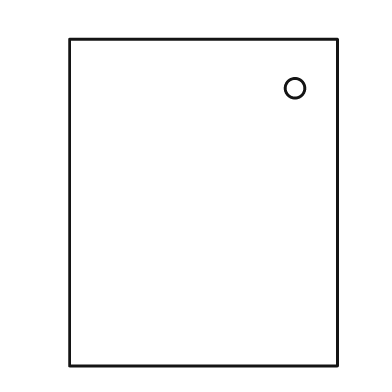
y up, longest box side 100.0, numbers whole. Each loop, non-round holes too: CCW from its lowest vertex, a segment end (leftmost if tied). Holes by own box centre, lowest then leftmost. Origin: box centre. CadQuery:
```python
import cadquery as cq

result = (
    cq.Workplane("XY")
    .moveTo(-41.0, -50.0)
    .lineTo(41.0, -50.0)
    .lineTo(41.0, 50.0)
    .lineTo(-41.0, 50.0)
    .close()
    .moveTo(28.0, 35.0)
    .circle(3.0)
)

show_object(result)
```